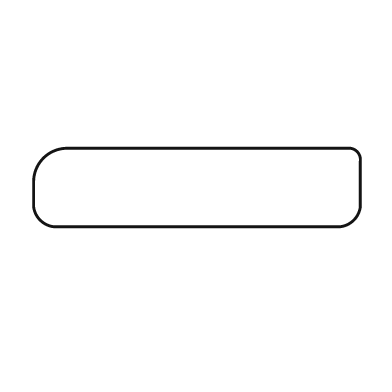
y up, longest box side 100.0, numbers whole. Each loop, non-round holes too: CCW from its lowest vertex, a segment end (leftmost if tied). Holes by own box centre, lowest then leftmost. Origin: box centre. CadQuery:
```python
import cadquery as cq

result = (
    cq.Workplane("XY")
    .moveTo(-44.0, -12.0)
    .lineTo(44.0, -12.0)
    .threePointArc((48.0, -10.0), (50.0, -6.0))
    .lineTo(50.0, 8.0)
    .threePointArc((49.0, 11.0), (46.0, 12.0))
    .lineTo(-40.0, 12.0)
    .threePointArc((-47.0, 9.0), (-50.0, 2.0))
    .lineTo(-50.0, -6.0)
    .threePointArc((-48.0, -10.0), (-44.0, -12.0))
    .close()
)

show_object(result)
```